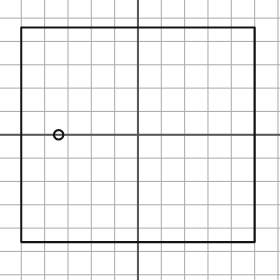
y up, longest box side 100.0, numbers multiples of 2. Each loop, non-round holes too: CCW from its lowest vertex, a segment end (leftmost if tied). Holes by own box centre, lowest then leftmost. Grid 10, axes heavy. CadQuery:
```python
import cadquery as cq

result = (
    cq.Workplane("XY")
    .moveTo(-50.0, -46.0)
    .lineTo(50.0, -46.0)
    .lineTo(50.0, 46.0)
    .lineTo(-50.0, 46.0)
    .close()
    .moveTo(-34.0, 0.0)
    .circle(2.0)
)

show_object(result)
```